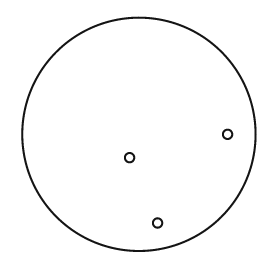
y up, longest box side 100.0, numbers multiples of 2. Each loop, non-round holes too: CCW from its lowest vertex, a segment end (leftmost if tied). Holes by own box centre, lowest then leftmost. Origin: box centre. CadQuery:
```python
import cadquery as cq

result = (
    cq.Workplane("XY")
    .moveTo(0.0, 0.0)
    .circle(50.0)
    .moveTo(8.0, -38.0)
    .circle(2.0)
    .moveTo(-4.0, -10.0)
    .circle(2.0)
    .moveTo(38.0, 0.0)
    .circle(2.0)
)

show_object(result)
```